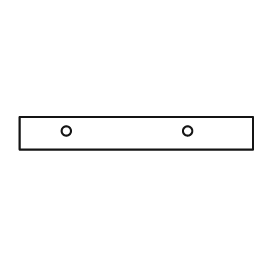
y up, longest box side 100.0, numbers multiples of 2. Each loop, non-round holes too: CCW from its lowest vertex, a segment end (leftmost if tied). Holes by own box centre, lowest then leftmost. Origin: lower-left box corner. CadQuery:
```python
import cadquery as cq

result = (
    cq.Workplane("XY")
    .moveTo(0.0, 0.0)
    .lineTo(100.0, 0.0)
    .lineTo(100.0, 14.0)
    .lineTo(0.0, 14.0)
    .close()
    .moveTo(20.0, 8.0)
    .circle(2.0)
    .moveTo(72.0, 8.0)
    .circle(2.0)
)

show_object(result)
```